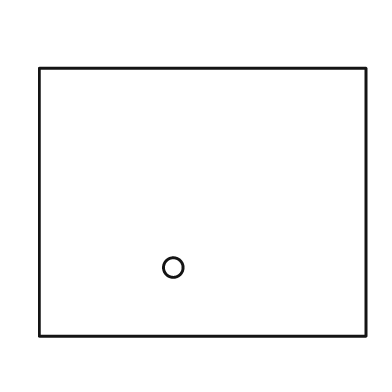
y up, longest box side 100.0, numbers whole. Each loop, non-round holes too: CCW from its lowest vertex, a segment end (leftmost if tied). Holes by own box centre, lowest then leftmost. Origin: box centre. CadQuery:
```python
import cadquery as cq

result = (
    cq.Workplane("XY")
    .moveTo(-50.0, -41.0)
    .lineTo(50.0, -41.0)
    .lineTo(50.0, 41.0)
    .lineTo(-50.0, 41.0)
    .close()
    .moveTo(-9.0, -20.0)
    .circle(3.0)
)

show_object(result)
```